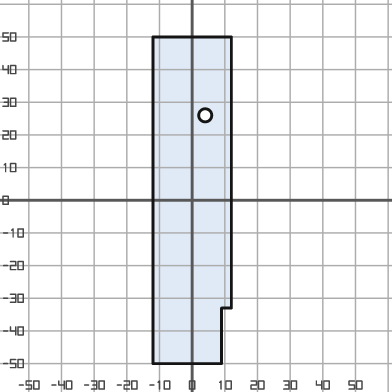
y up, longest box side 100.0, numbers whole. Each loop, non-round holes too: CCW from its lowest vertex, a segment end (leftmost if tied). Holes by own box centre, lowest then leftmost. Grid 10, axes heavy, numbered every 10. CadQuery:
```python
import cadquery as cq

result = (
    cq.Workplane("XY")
    .moveTo(-12.0, -50.0)
    .lineTo(9.0, -50.0)
    .lineTo(9.0, -33.0)
    .lineTo(12.0, -33.0)
    .lineTo(12.0, 50.0)
    .lineTo(-12.0, 50.0)
    .close()
    .moveTo(4.0, 26.0)
    .circle(2.0)
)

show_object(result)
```